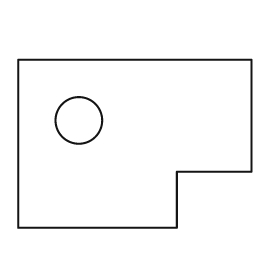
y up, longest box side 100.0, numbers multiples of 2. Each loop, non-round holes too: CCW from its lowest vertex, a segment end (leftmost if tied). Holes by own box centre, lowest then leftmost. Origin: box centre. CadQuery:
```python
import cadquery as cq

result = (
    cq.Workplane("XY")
    .moveTo(-50.0, -36.0)
    .lineTo(18.0, -36.0)
    .lineTo(18.0, -12.0)
    .lineTo(50.0, -12.0)
    .lineTo(50.0, 36.0)
    .lineTo(-50.0, 36.0)
    .close()
    .moveTo(-24.0, 10.0)
    .circle(10.0)
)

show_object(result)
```